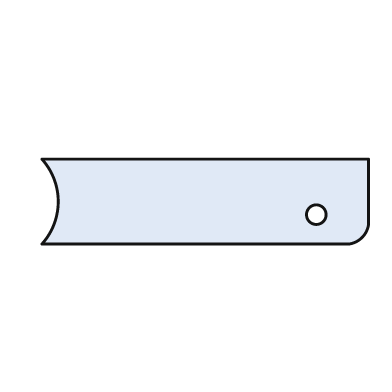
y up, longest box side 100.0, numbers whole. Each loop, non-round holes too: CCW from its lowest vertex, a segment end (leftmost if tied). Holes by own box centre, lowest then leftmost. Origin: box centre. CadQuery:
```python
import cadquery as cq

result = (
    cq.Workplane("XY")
    .moveTo(-50.0, -13.0)
    .lineTo(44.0, -13.0)
    .threePointArc((48.0, -11.0), (50.0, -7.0))
    .lineTo(50.0, 13.0)
    .lineTo(-50.0, 13.0)
    .threePointArc((-45.0, 0.0), (-50.0, -13.0))
    .close()
    .moveTo(34.0, -4.0)
    .circle(3.0)
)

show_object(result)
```